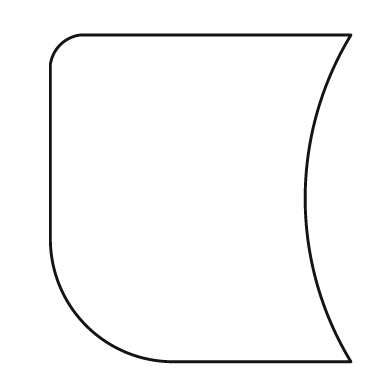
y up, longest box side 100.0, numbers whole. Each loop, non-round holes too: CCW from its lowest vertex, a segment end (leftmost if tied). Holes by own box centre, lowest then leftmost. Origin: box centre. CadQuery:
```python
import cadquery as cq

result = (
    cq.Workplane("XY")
    .moveTo(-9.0, -50.0)
    .lineTo(46.0, -50.0)
    .threePointArc((32.0, 0.0), (46.0, 50.0))
    .lineTo(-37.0, 50.0)
    .threePointArc((-43.0, 47.0), (-46.0, 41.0))
    .lineTo(-46.0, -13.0)
    .threePointArc((-35.0, -39.0), (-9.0, -50.0))
    .close()
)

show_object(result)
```